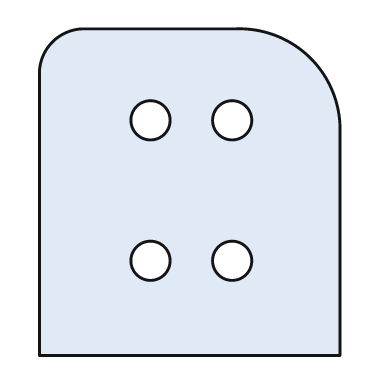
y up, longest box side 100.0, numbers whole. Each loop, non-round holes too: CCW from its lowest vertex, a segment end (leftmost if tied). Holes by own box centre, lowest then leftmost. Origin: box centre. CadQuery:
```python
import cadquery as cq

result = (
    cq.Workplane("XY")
    .moveTo(-46.0, -50.0)
    .lineTo(46.0, -50.0)
    .lineTo(46.0, 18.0)
    .threePointArc((37.0, 41.0), (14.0, 50.0))
    .lineTo(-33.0, 50.0)
    .threePointArc((-42.0, 46.0), (-46.0, 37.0))
    .close()
    .moveTo(-12.0, -21.0)
    .circle(6.0)
    .moveTo(13.0, -21.0)
    .circle(6.0)
    .moveTo(-12.0, 22.0)
    .circle(6.0)
    .moveTo(13.0, 22.0)
    .circle(6.0)
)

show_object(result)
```